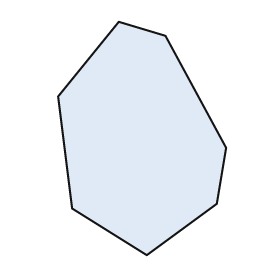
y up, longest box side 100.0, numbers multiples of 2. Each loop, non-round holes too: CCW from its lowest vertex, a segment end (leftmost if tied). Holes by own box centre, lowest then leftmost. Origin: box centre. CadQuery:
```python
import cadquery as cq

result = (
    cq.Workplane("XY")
    .moveTo(2.0, -50.0)
    .lineTo(32.0, -28.0)
    .lineTo(36.0, -4.0)
    .lineTo(10.0, 44.0)
    .lineTo(-10.0, 50.0)
    .lineTo(-36.0, 18.0)
    .lineTo(-30.0, -30.0)
    .close()
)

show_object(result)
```